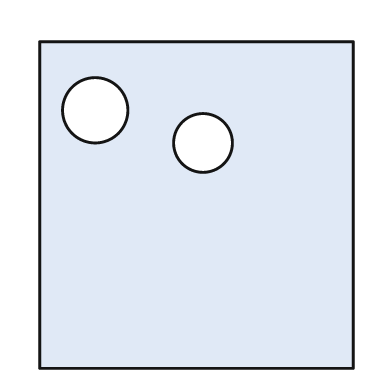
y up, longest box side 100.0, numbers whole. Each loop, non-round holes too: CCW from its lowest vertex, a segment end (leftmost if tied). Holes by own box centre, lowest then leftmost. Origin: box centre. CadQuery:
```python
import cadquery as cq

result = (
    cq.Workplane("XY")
    .moveTo(-48.0, -50.0)
    .lineTo(48.0, -50.0)
    .lineTo(48.0, 50.0)
    .lineTo(-48.0, 50.0)
    .close()
    .moveTo(2.0, 19.0)
    .circle(9.0)
    .moveTo(-31.0, 29.0)
    .circle(10.0)
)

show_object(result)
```